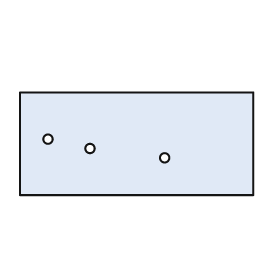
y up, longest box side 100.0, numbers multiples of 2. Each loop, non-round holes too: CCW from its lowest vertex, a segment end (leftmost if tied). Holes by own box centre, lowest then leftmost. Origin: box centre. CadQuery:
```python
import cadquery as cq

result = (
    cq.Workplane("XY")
    .moveTo(-50.0, -22.0)
    .lineTo(50.0, -22.0)
    .lineTo(50.0, 22.0)
    .lineTo(-50.0, 22.0)
    .close()
    .moveTo(12.0, -6.0)
    .circle(2.0)
    .moveTo(-20.0, -2.0)
    .circle(2.0)
    .moveTo(-38.0, 2.0)
    .circle(2.0)
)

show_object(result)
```